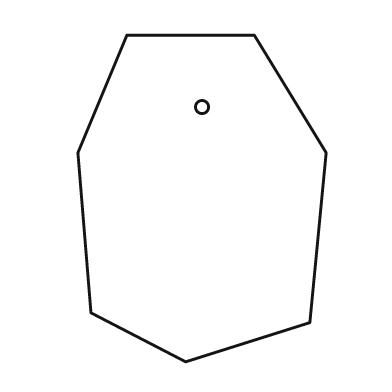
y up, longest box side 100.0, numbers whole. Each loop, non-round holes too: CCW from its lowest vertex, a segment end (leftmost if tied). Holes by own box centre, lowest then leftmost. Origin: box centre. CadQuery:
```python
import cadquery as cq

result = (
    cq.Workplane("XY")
    .moveTo(-5.0, -50.0)
    .lineTo(33.0, -38.0)
    .lineTo(38.0, 14.0)
    .lineTo(16.0, 50.0)
    .lineTo(-23.0, 50.0)
    .lineTo(-38.0, 14.0)
    .lineTo(-34.0, -35.0)
    .close()
    .moveTo(0.0, 28.0)
    .circle(2.0)
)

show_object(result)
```